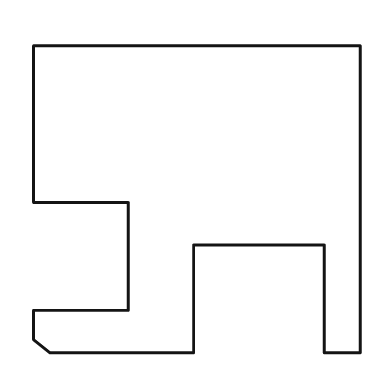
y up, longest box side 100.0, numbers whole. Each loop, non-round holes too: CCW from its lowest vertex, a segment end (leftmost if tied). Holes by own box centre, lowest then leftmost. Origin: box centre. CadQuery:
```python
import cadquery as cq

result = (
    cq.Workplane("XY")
    .moveTo(-45.0, -47.0)
    .lineTo(-1.0, -47.0)
    .lineTo(-1.0, -14.0)
    .lineTo(39.0, -14.0)
    .lineTo(39.0, -47.0)
    .lineTo(50.0, -47.0)
    .lineTo(50.0, 47.0)
    .lineTo(-50.0, 47.0)
    .lineTo(-50.0, -1.0)
    .lineTo(-21.0, -1.0)
    .lineTo(-21.0, -34.0)
    .lineTo(-50.0, -34.0)
    .lineTo(-50.0, -43.0)
    .close()
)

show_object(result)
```